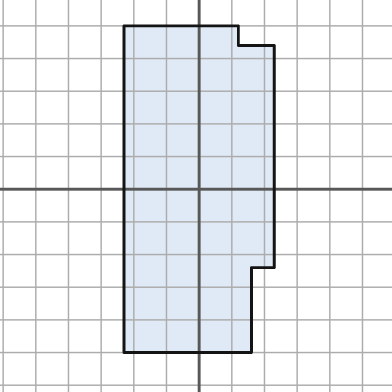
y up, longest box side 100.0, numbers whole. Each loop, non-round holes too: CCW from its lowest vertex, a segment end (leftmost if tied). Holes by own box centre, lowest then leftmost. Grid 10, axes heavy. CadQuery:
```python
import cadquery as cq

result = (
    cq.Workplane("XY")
    .moveTo(-23.0, -50.0)
    .lineTo(16.0, -50.0)
    .lineTo(16.0, -24.0)
    .lineTo(23.0, -24.0)
    .lineTo(23.0, 44.0)
    .lineTo(12.0, 44.0)
    .lineTo(12.0, 50.0)
    .lineTo(-23.0, 50.0)
    .close()
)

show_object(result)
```